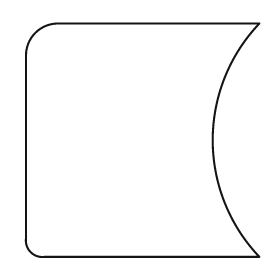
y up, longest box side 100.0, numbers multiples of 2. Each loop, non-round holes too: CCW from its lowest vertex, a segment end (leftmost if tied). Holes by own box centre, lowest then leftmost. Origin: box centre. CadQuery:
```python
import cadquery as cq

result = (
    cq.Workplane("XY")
    .moveTo(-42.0, -50.0)
    .lineTo(50.0, -50.0)
    .threePointArc((30.0, 0.0), (50.0, 50.0))
    .lineTo(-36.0, 50.0)
    .threePointArc((-46.0, 46.0), (-50.0, 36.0))
    .lineTo(-50.0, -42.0)
    .threePointArc((-48.0, -48.0), (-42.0, -50.0))
    .close()
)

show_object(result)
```